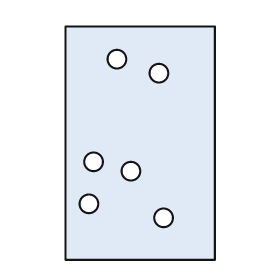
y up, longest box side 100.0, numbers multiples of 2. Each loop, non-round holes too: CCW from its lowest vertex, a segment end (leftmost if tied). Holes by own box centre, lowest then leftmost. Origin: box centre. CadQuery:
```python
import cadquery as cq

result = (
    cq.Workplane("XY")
    .moveTo(-32.0, -50.0)
    .lineTo(32.0, -50.0)
    .lineTo(32.0, 50.0)
    .lineTo(-32.0, 50.0)
    .close()
    .moveTo(10.0, -32.0)
    .circle(4.0)
    .moveTo(-22.0, -26.0)
    .circle(4.0)
    .moveTo(-4.0, -12.0)
    .circle(4.0)
    .moveTo(-20.0, -8.0)
    .circle(4.0)
    .moveTo(8.0, 30.0)
    .circle(4.0)
    .moveTo(-10.0, 36.0)
    .circle(4.0)
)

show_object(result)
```